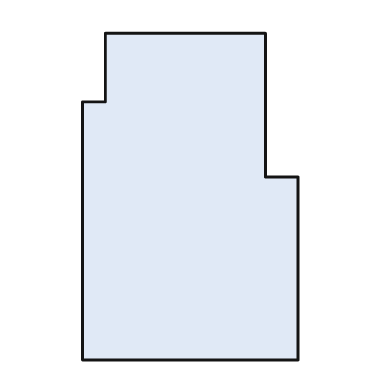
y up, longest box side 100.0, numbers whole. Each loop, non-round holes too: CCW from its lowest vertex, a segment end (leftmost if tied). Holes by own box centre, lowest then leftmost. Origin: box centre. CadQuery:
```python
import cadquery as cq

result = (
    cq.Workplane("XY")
    .moveTo(-33.0, -50.0)
    .lineTo(33.0, -50.0)
    .lineTo(33.0, 6.0)
    .lineTo(23.0, 6.0)
    .lineTo(23.0, 50.0)
    .lineTo(-26.0, 50.0)
    .lineTo(-26.0, 29.0)
    .lineTo(-33.0, 29.0)
    .close()
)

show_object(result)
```